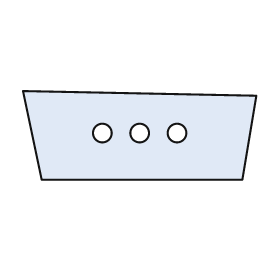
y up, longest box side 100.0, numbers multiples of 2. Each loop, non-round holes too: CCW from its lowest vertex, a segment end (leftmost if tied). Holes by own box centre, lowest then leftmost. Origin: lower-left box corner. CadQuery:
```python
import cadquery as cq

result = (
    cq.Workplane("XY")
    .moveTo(8.0, 0.0)
    .lineTo(94.0, 0.0)
    .lineTo(100.0, 36.0)
    .lineTo(0.0, 38.0)
    .close()
    .moveTo(34.0, 20.0)
    .circle(4.0)
    .moveTo(50.0, 20.0)
    .circle(4.0)
    .moveTo(66.0, 20.0)
    .circle(4.0)
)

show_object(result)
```